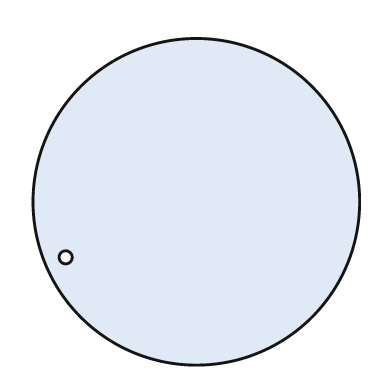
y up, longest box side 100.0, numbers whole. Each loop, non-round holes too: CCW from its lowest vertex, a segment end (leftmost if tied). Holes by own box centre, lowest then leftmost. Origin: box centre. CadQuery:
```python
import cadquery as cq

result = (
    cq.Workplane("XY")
    .moveTo(0.0, 0.0)
    .circle(50.0)
    .moveTo(-40.0, -17.0)
    .circle(2.0)
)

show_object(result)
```